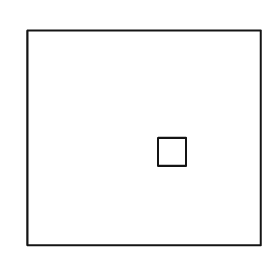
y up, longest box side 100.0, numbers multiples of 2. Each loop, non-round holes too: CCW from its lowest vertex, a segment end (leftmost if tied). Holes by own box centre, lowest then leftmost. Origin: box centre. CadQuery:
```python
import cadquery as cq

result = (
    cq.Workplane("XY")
    .moveTo(-50.0, -46.0)
    .lineTo(50.0, -46.0)
    .lineTo(50.0, 46.0)
    .lineTo(-50.0, 46.0)
    .close()
    .moveTo(6.0, -12.0)
    .lineTo(18.0, -12.0)
    .lineTo(18.0, 0.0)
    .lineTo(6.0, 0.0)
    .close()
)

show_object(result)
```